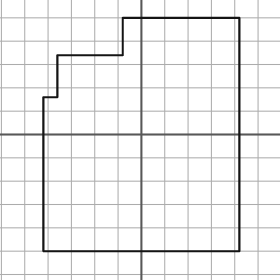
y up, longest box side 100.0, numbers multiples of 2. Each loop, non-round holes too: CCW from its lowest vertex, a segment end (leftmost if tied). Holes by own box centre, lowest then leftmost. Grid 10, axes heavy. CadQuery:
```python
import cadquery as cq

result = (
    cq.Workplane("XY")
    .moveTo(-42.0, -50.0)
    .lineTo(42.0, -50.0)
    .lineTo(42.0, 50.0)
    .lineTo(-8.0, 50.0)
    .lineTo(-8.0, 34.0)
    .lineTo(-36.0, 34.0)
    .lineTo(-36.0, 16.0)
    .lineTo(-42.0, 16.0)
    .close()
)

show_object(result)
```